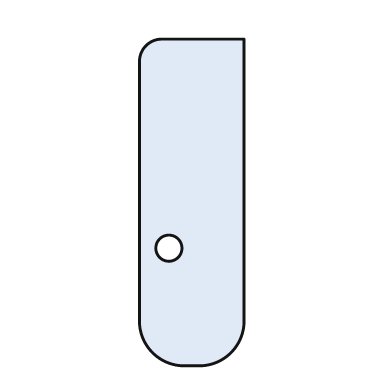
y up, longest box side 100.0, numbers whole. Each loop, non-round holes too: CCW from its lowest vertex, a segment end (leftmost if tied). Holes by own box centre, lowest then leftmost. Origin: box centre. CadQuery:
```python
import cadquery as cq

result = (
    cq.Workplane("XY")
    .moveTo(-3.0, -50.0)
    .lineTo(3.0, -50.0)
    .threePointArc((12.0, -46.0), (16.0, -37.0))
    .lineTo(16.0, 50.0)
    .lineTo(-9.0, 50.0)
    .threePointArc((-14.0, 48.0), (-16.0, 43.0))
    .lineTo(-16.0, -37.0)
    .threePointArc((-12.0, -46.0), (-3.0, -50.0))
    .close()
    .moveTo(-7.0, -14.0)
    .circle(4.0)
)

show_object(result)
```